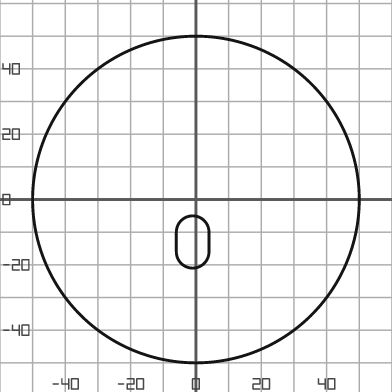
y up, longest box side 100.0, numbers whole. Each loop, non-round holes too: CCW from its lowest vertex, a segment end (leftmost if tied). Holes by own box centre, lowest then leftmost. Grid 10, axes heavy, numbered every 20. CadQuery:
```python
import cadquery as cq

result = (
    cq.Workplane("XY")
    .moveTo(0.0, 0.0)
    .circle(50.0)
    .moveTo(-6.0, -16.0)
    .threePointArc((-1.0, -21.0), (4.0, -16.0))
    .lineTo(4.0, -10.0)
    .threePointArc((-1.0, -5.0), (-6.0, -10.0))
    .close()
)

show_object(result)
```